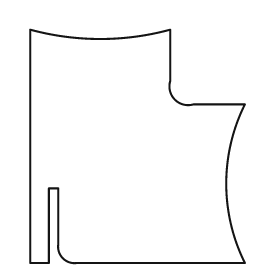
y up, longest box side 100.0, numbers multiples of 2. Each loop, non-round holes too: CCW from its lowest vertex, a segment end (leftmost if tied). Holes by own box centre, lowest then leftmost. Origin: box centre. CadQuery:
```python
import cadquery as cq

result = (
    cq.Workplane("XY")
    .moveTo(-46.0, -50.0)
    .lineTo(-38.0, -50.0)
    .lineTo(-38.0, -18.0)
    .lineTo(-34.0, -18.0)
    .lineTo(-34.0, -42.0)
    .threePointArc((-32.0, -48.0), (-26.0, -50.0))
    .lineTo(46.0, -50.0)
    .threePointArc((38.0, -16.0), (46.0, 18.0))
    .lineTo(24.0, 18.0)
    .threePointArc((16.0, 20.0), (14.0, 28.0))
    .lineTo(14.0, 50.0)
    .threePointArc((-16.0, 46.0), (-46.0, 50.0))
    .close()
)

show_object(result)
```